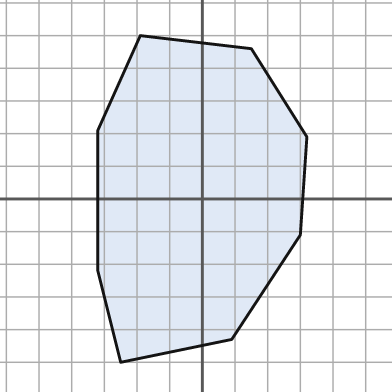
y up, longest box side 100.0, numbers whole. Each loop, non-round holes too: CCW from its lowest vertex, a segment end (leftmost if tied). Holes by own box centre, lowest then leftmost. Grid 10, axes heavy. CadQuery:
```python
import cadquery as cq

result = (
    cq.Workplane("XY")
    .moveTo(-25.0, -50.0)
    .lineTo(9.0, -43.0)
    .lineTo(30.0, -11.0)
    .lineTo(32.0, 19.0)
    .lineTo(15.0, 46.0)
    .lineTo(-19.0, 50.0)
    .lineTo(-32.0, 21.0)
    .lineTo(-32.0, -22.0)
    .close()
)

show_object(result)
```